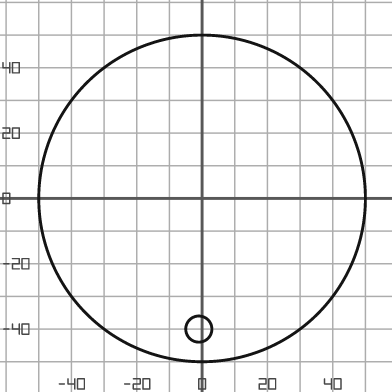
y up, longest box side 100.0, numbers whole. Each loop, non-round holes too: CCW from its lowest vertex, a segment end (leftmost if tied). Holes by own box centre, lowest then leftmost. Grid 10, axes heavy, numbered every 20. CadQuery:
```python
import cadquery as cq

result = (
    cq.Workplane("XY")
    .moveTo(0.0, 0.0)
    .circle(50.0)
    .moveTo(-1.0, -40.0)
    .circle(4.0)
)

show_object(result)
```